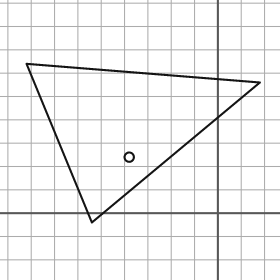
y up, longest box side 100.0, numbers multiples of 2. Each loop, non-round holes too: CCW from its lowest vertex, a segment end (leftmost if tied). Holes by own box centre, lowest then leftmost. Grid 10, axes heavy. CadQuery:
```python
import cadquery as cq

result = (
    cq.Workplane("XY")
    .moveTo(-54.0, -4.0)
    .lineTo(18.0, 56.0)
    .lineTo(-82.0, 64.0)
    .close()
    .moveTo(-38.0, 24.0)
    .circle(2.0)
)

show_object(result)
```